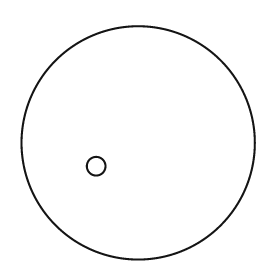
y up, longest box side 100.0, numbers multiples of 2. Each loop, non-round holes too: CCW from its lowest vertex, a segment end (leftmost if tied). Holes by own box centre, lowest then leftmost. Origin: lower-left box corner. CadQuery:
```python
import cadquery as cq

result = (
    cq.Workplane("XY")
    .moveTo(50.0, 50.0)
    .circle(50.0)
    .moveTo(32.0, 40.0)
    .circle(4.0)
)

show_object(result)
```